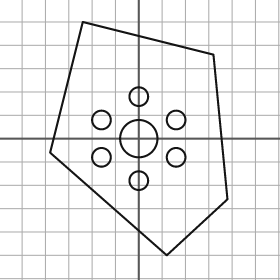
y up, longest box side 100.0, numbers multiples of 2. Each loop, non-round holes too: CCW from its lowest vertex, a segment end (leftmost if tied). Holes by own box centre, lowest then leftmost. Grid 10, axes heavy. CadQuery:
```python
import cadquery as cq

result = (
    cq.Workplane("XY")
    .moveTo(12.0, -50.0)
    .lineTo(38.0, -26.0)
    .lineTo(32.0, 36.0)
    .lineTo(-24.0, 50.0)
    .lineTo(-38.0, -6.0)
    .close()
    .moveTo(0.0, -18.0)
    .circle(4.0)
    .moveTo(-16.0, -8.0)
    .circle(4.0)
    .moveTo(16.0, -8.0)
    .circle(4.0)
    .moveTo(0.0, 0.0)
    .circle(8.0)
    .moveTo(-16.0, 8.0)
    .circle(4.0)
    .moveTo(16.0, 8.0)
    .circle(4.0)
    .moveTo(0.0, 18.0)
    .circle(4.0)
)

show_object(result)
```